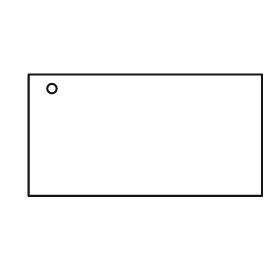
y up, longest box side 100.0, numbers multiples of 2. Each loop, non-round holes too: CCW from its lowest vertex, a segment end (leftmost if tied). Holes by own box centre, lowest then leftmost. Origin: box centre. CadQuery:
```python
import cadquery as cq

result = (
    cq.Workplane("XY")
    .moveTo(-50.0, -26.0)
    .lineTo(50.0, -26.0)
    .lineTo(50.0, 26.0)
    .lineTo(-50.0, 26.0)
    .close()
    .moveTo(-40.0, 20.0)
    .circle(2.0)
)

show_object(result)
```